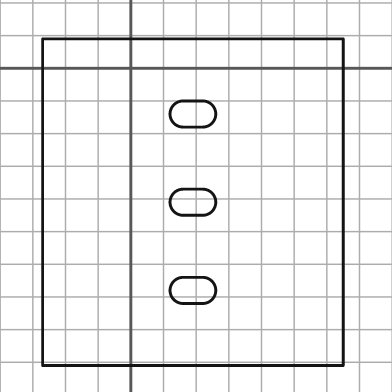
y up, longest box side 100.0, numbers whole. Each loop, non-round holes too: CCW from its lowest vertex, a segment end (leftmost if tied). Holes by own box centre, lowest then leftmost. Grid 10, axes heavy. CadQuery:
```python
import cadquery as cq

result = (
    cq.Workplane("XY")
    .moveTo(-27.0, -91.0)
    .lineTo(65.0, -91.0)
    .lineTo(65.0, 9.0)
    .lineTo(-27.0, 9.0)
    .close()
    .moveTo(16.0, -72.0)
    .lineTo(22.0, -72.0)
    .threePointArc((26.0, -68.0), (22.0, -64.0))
    .lineTo(16.0, -64.0)
    .threePointArc((12.0, -68.0), (16.0, -72.0))
    .close()
    .moveTo(16.0, -45.0)
    .lineTo(22.0, -45.0)
    .threePointArc((26.0, -41.0), (22.0, -37.0))
    .lineTo(16.0, -37.0)
    .threePointArc((12.0, -41.0), (16.0, -45.0))
    .close()
    .moveTo(16.0, -18.0)
    .lineTo(22.0, -18.0)
    .threePointArc((26.0, -14.0), (22.0, -10.0))
    .lineTo(16.0, -10.0)
    .threePointArc((12.0, -14.0), (16.0, -18.0))
    .close()
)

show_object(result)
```